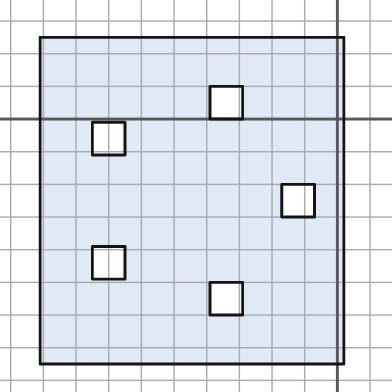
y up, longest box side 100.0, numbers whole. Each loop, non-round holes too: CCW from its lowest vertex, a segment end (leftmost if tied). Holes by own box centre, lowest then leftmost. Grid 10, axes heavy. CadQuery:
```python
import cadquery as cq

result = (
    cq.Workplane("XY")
    .moveTo(-91.0, -75.0)
    .lineTo(2.0, -75.0)
    .lineTo(2.0, 25.0)
    .lineTo(-91.0, 25.0)
    .close()
    .moveTo(-39.0, -60.0)
    .lineTo(-29.0, -60.0)
    .lineTo(-29.0, -50.0)
    .lineTo(-39.0, -50.0)
    .close()
    .moveTo(-75.0, -49.0)
    .lineTo(-65.0, -49.0)
    .lineTo(-65.0, -39.0)
    .lineTo(-75.0, -39.0)
    .close()
    .moveTo(-17.0, -30.0)
    .lineTo(-7.0, -30.0)
    .lineTo(-7.0, -20.0)
    .lineTo(-17.0, -20.0)
    .close()
    .moveTo(-75.0, -11.0)
    .lineTo(-65.0, -11.0)
    .lineTo(-65.0, -1.0)
    .lineTo(-75.0, -1.0)
    .close()
    .moveTo(-39.0, 0.0)
    .lineTo(-29.0, 0.0)
    .lineTo(-29.0, 10.0)
    .lineTo(-39.0, 10.0)
    .close()
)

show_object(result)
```